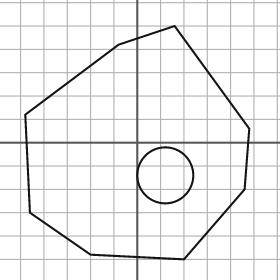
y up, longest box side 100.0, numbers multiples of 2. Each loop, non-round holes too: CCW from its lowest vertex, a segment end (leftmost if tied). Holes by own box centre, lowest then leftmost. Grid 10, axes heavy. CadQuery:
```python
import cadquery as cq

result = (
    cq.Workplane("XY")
    .moveTo(20.0, -50.0)
    .lineTo(46.0, -20.0)
    .lineTo(48.0, 6.0)
    .lineTo(16.0, 50.0)
    .lineTo(-8.0, 42.0)
    .lineTo(-48.0, 12.0)
    .lineTo(-46.0, -30.0)
    .lineTo(-20.0, -48.0)
    .close()
    .moveTo(12.0, -14.0)
    .circle(12.0)
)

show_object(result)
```